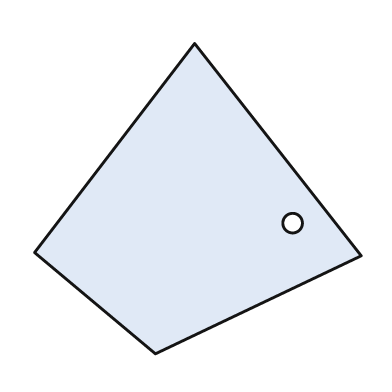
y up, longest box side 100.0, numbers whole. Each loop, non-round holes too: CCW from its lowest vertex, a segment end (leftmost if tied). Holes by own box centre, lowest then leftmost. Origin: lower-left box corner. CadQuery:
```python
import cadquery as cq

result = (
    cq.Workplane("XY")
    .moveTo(37.0, 0.0)
    .lineTo(100.0, 30.0)
    .lineTo(49.0, 95.0)
    .lineTo(0.0, 31.0)
    .close()
    .moveTo(79.0, 40.0)
    .circle(3.0)
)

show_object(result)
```